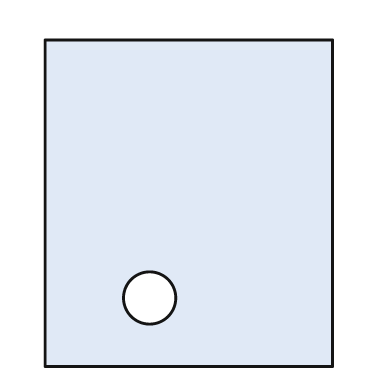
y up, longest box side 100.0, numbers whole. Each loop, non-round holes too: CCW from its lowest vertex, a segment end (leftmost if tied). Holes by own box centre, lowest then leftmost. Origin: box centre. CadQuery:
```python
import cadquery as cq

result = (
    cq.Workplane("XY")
    .moveTo(-44.0, -50.0)
    .lineTo(44.0, -50.0)
    .lineTo(44.0, 50.0)
    .lineTo(-44.0, 50.0)
    .close()
    .moveTo(-12.0, -29.0)
    .circle(8.0)
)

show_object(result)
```